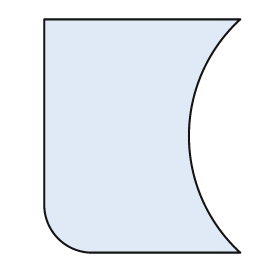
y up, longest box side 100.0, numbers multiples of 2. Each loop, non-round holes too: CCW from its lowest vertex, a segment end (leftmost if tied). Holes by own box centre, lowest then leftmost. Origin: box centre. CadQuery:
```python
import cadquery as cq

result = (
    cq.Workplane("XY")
    .moveTo(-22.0, -50.0)
    .lineTo(42.0, -50.0)
    .threePointArc((20.0, 0.0), (42.0, 50.0))
    .lineTo(-42.0, 50.0)
    .lineTo(-42.0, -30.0)
    .threePointArc((-36.0, -44.0), (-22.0, -50.0))
    .close()
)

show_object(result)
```